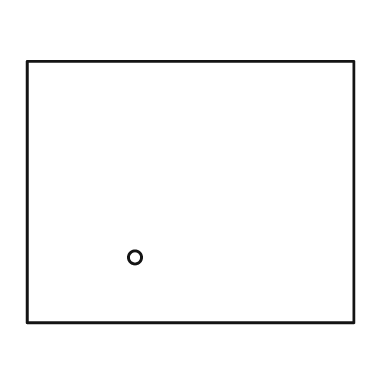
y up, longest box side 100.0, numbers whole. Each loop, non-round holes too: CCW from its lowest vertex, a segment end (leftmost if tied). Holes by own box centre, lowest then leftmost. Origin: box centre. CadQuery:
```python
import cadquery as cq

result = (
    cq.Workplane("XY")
    .moveTo(-50.0, -40.0)
    .lineTo(50.0, -40.0)
    .lineTo(50.0, 40.0)
    .lineTo(-50.0, 40.0)
    .close()
    .moveTo(-17.0, -20.0)
    .circle(2.0)
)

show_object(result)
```